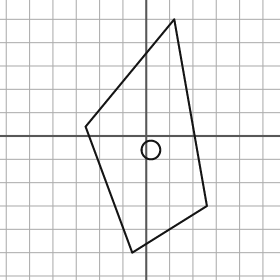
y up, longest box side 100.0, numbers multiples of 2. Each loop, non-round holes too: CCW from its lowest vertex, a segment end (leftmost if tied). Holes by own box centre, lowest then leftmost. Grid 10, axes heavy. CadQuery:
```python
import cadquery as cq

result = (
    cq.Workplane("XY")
    .moveTo(-6.0, -50.0)
    .lineTo(26.0, -30.0)
    .lineTo(12.0, 50.0)
    .lineTo(-26.0, 4.0)
    .close()
    .moveTo(2.0, -6.0)
    .circle(4.0)
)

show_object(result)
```